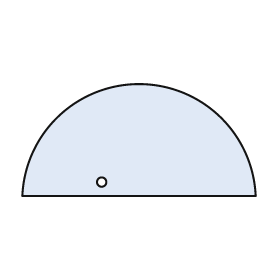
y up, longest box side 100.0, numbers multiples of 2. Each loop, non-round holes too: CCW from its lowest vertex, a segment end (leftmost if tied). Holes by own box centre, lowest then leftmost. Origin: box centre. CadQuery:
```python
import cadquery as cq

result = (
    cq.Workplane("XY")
    .moveTo(-50.0, -24.0)
    .lineTo(50.0, -24.0)
    .threePointArc((0.0, 24.0), (-50.0, -24.0))
    .close()
    .moveTo(-16.0, -18.0)
    .circle(2.0)
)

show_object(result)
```